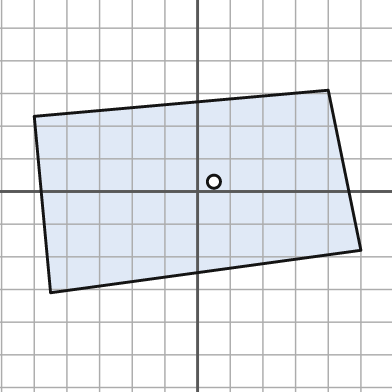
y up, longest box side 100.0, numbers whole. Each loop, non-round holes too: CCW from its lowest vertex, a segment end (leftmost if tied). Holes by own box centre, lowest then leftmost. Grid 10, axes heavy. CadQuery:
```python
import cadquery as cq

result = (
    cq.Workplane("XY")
    .moveTo(-45.0, -31.0)
    .lineTo(50.0, -18.0)
    .lineTo(40.0, 31.0)
    .lineTo(-50.0, 23.0)
    .close()
    .moveTo(5.0, 3.0)
    .circle(2.0)
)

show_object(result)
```